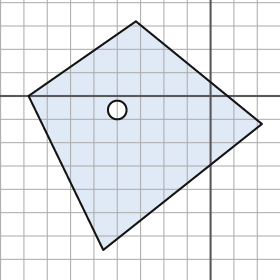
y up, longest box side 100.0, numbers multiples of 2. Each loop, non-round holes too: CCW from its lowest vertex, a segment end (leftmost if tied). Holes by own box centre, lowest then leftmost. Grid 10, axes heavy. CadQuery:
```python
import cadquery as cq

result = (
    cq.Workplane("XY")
    .moveTo(-46.0, -66.0)
    .lineTo(22.0, -12.0)
    .lineTo(-32.0, 32.0)
    .lineTo(-78.0, 0.0)
    .close()
    .moveTo(-40.0, -6.0)
    .circle(4.0)
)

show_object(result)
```